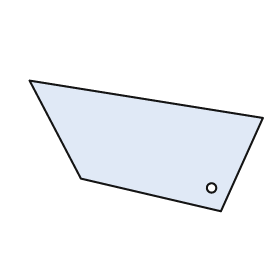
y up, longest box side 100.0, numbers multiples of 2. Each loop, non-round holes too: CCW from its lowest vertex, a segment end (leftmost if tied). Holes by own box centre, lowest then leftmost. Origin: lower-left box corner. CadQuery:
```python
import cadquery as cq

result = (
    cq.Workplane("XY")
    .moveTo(82.0, 0.0)
    .lineTo(100.0, 40.0)
    .lineTo(0.0, 56.0)
    .lineTo(22.0, 14.0)
    .close()
    .moveTo(78.0, 10.0)
    .circle(2.0)
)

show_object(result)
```